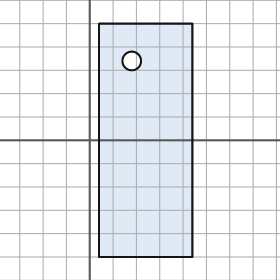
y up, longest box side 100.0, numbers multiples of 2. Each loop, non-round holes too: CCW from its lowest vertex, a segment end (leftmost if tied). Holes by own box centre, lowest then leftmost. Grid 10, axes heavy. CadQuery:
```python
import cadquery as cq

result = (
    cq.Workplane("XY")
    .moveTo(4.0, -50.0)
    .lineTo(44.0, -50.0)
    .lineTo(44.0, 50.0)
    .lineTo(4.0, 50.0)
    .close()
    .moveTo(18.0, 34.0)
    .circle(4.0)
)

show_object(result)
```